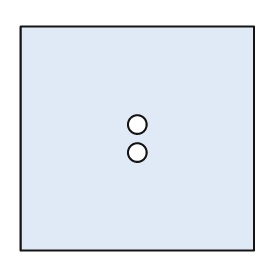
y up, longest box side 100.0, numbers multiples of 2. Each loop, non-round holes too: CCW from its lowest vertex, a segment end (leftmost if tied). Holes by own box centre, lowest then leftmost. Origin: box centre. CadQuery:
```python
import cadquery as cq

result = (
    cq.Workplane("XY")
    .moveTo(-50.0, -48.0)
    .lineTo(50.0, -48.0)
    .lineTo(50.0, 48.0)
    .lineTo(-50.0, 48.0)
    .close()
    .moveTo(0.0, -6.0)
    .circle(4.0)
    .moveTo(0.0, 6.0)
    .circle(4.0)
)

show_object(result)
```